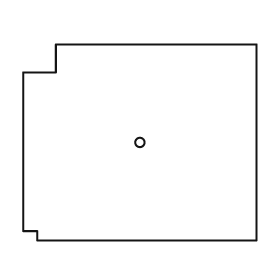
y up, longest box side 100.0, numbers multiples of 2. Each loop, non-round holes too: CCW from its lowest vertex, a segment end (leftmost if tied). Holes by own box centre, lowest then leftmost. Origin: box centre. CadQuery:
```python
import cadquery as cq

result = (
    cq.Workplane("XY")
    .moveTo(-44.0, -42.0)
    .lineTo(50.0, -42.0)
    .lineTo(50.0, 42.0)
    .lineTo(-36.0, 42.0)
    .lineTo(-36.0, 30.0)
    .lineTo(-50.0, 30.0)
    .lineTo(-50.0, -38.0)
    .lineTo(-44.0, -38.0)
    .close()
    .moveTo(0.0, 0.0)
    .circle(2.0)
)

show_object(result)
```